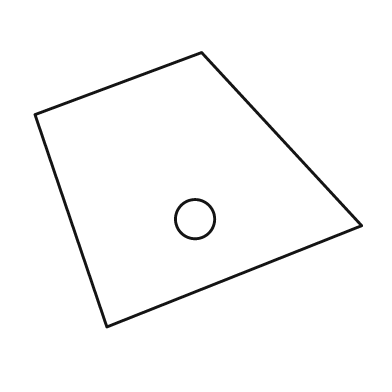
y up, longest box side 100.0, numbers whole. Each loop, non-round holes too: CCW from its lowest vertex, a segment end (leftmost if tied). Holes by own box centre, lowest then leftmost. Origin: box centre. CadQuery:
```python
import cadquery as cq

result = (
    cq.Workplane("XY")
    .moveTo(-28.0, -42.0)
    .lineTo(50.0, -11.0)
    .lineTo(1.0, 42.0)
    .lineTo(-50.0, 23.0)
    .close()
    .moveTo(-1.0, -9.0)
    .circle(6.0)
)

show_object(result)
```